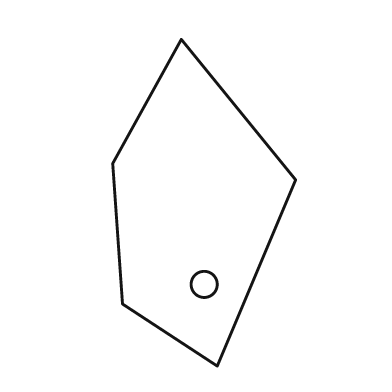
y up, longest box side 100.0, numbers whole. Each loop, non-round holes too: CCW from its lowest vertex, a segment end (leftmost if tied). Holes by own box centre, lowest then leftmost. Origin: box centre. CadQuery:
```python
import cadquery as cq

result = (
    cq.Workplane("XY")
    .moveTo(4.0, -50.0)
    .lineTo(28.0, 7.0)
    .lineTo(-7.0, 50.0)
    .lineTo(-28.0, 12.0)
    .lineTo(-25.0, -31.0)
    .close()
    .moveTo(0.0, -25.0)
    .circle(4.0)
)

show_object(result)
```